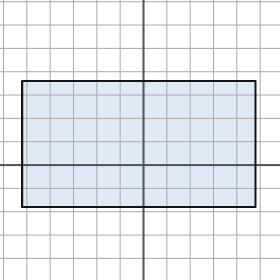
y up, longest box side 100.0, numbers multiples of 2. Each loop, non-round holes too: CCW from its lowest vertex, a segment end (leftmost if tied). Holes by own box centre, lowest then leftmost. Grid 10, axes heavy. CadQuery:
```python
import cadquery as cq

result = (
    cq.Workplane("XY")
    .moveTo(-52.0, -18.0)
    .lineTo(48.0, -18.0)
    .lineTo(48.0, 36.0)
    .lineTo(-52.0, 36.0)
    .close()
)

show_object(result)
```